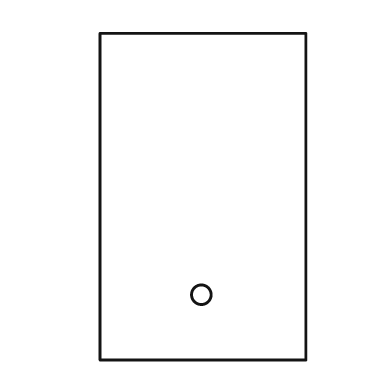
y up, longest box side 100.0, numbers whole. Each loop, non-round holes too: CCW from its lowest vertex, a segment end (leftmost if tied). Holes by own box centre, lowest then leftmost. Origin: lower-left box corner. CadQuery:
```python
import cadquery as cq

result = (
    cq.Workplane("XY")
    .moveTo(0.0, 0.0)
    .lineTo(63.0, 0.0)
    .lineTo(63.0, 100.0)
    .lineTo(0.0, 100.0)
    .close()
    .moveTo(31.0, 20.0)
    .circle(3.0)
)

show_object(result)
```